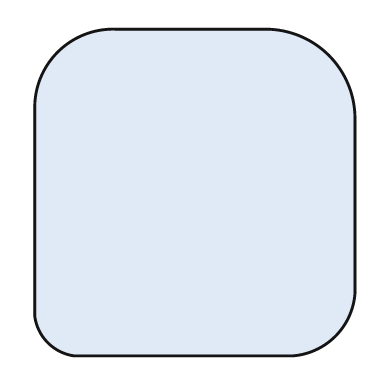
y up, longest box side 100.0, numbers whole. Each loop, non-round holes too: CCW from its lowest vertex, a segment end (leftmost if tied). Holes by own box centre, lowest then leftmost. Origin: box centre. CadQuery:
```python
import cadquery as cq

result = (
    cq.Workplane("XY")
    .moveTo(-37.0, -50.0)
    .lineTo(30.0, -50.0)
    .threePointArc((43.0, -44.0), (49.0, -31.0))
    .lineTo(49.0, 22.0)
    .threePointArc((41.0, 42.0), (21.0, 50.0))
    .lineTo(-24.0, 50.0)
    .threePointArc((-42.0, 43.0), (-49.0, 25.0))
    .lineTo(-49.0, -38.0)
    .threePointArc((-45.0, -46.0), (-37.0, -50.0))
    .close()
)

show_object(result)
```